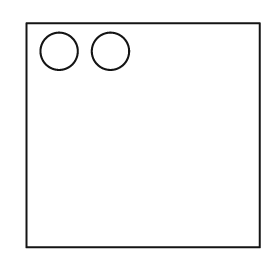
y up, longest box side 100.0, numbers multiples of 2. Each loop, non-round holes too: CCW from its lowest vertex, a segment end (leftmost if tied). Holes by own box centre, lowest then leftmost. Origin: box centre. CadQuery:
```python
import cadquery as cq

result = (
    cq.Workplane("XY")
    .moveTo(-50.0, -48.0)
    .lineTo(50.0, -48.0)
    .lineTo(50.0, 48.0)
    .lineTo(-50.0, 48.0)
    .close()
    .moveTo(-36.0, 36.0)
    .circle(8.0)
    .moveTo(-14.0, 36.0)
    .circle(8.0)
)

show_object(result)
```